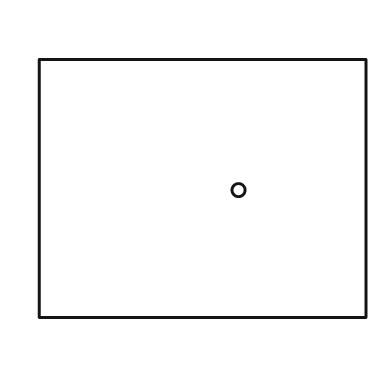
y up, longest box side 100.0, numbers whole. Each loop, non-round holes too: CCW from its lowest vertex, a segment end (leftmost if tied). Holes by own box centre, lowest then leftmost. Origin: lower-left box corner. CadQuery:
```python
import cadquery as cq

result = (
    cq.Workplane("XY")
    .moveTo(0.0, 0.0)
    .lineTo(100.0, 0.0)
    .lineTo(100.0, 79.0)
    .lineTo(0.0, 79.0)
    .close()
    .moveTo(61.0, 39.0)
    .circle(2.0)
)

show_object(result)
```